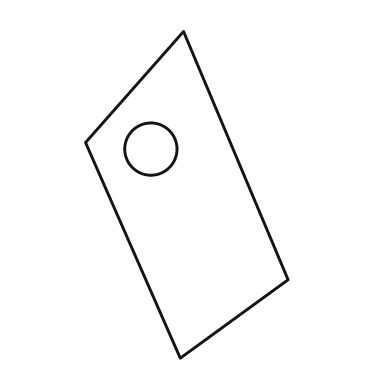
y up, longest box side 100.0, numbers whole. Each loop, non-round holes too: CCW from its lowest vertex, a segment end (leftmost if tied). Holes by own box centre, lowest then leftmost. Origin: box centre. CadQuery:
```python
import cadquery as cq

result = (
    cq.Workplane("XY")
    .moveTo(-2.0, -50.0)
    .lineTo(31.0, -26.0)
    .lineTo(-1.0, 50.0)
    .lineTo(-31.0, 16.0)
    .close()
    .moveTo(-11.0, 14.0)
    .circle(8.0)
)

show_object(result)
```